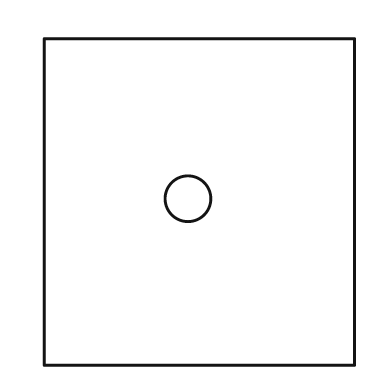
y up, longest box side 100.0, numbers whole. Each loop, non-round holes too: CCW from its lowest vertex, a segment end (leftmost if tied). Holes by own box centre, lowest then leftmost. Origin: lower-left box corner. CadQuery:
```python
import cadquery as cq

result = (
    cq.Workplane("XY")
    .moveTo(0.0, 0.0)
    .lineTo(95.0, 0.0)
    .lineTo(95.0, 100.0)
    .lineTo(0.0, 100.0)
    .close()
    .moveTo(44.0, 51.0)
    .circle(7.0)
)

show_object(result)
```